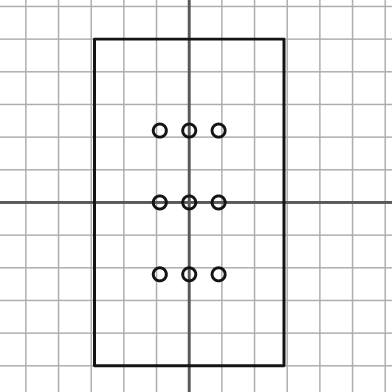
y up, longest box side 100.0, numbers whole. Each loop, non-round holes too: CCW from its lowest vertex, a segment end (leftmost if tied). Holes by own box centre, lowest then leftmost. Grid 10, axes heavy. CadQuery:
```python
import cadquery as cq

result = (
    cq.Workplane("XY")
    .moveTo(-29.0, -50.0)
    .lineTo(29.0, -50.0)
    .lineTo(29.0, 50.0)
    .lineTo(-29.0, 50.0)
    .close()
    .moveTo(-9.0, -22.0)
    .circle(2.0)
    .moveTo(0.0, -22.0)
    .circle(2.0)
    .moveTo(9.0, -22.0)
    .circle(2.0)
    .moveTo(-9.0, 0.0)
    .circle(2.0)
    .moveTo(0.0, 0.0)
    .circle(2.0)
    .moveTo(9.0, 0.0)
    .circle(2.0)
    .moveTo(-9.0, 22.0)
    .circle(2.0)
    .moveTo(0.0, 22.0)
    .circle(2.0)
    .moveTo(9.0, 22.0)
    .circle(2.0)
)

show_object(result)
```